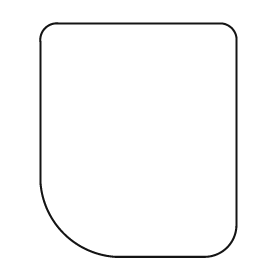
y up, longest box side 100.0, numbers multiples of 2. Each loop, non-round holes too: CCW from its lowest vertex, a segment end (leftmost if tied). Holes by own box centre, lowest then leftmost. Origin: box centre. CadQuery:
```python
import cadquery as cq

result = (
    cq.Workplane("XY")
    .moveTo(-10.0, -50.0)
    .lineTo(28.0, -50.0)
    .threePointArc((38.0, -46.0), (42.0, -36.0))
    .lineTo(42.0, 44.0)
    .threePointArc((40.0, 48.0), (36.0, 50.0))
    .lineTo(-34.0, 50.0)
    .threePointArc((-40.0, 48.0), (-42.0, 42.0))
    .lineTo(-42.0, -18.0)
    .threePointArc((-32.0, -40.0), (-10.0, -50.0))
    .close()
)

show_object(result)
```